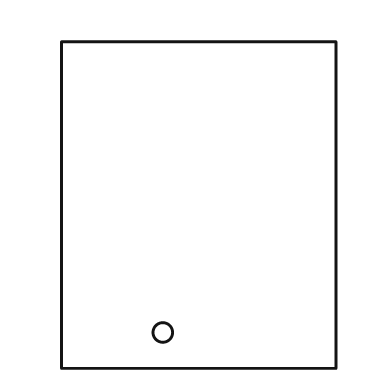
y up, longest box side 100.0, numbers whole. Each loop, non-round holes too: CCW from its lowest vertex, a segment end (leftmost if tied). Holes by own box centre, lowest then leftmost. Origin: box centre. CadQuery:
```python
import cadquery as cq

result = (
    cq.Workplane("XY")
    .moveTo(-42.0, -50.0)
    .lineTo(42.0, -50.0)
    .lineTo(42.0, 50.0)
    .lineTo(-42.0, 50.0)
    .close()
    .moveTo(-11.0, -39.0)
    .circle(3.0)
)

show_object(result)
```